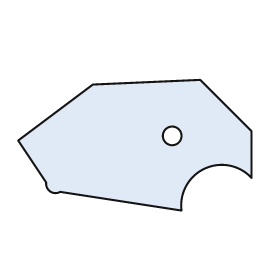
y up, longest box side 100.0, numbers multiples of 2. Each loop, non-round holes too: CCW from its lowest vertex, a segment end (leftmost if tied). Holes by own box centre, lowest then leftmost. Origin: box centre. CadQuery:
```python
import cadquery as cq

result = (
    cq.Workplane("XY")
    .moveTo(20.0, -28.0)
    .threePointArc((30.0, -10.0), (50.0, -14.0))
    .lineTo(50.0, 6.0)
    .lineTo(28.0, 28.0)
    .lineTo(-18.0, 26.0)
    .lineTo(-50.0, 2.0)
    .lineTo(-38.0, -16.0)
    .threePointArc((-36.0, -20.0), (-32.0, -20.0))
    .close()
    .moveTo(16.0, 4.0)
    .circle(4.0)
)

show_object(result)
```